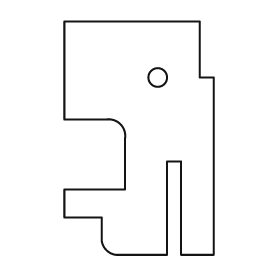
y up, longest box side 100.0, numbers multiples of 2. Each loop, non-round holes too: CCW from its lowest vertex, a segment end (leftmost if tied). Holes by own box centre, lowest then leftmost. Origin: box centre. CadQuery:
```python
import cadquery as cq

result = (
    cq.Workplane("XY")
    .moveTo(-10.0, -50.0)
    .lineTo(12.0, -50.0)
    .lineTo(12.0, -10.0)
    .lineTo(18.0, -10.0)
    .lineTo(18.0, -50.0)
    .lineTo(32.0, -50.0)
    .lineTo(32.0, 26.0)
    .lineTo(26.0, 26.0)
    .lineTo(26.0, 50.0)
    .lineTo(-32.0, 50.0)
    .lineTo(-32.0, 8.0)
    .lineTo(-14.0, 8.0)
    .threePointArc((-8.0, 6.0), (-6.0, 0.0))
    .lineTo(-6.0, -22.0)
    .lineTo(-32.0, -22.0)
    .lineTo(-32.0, -34.0)
    .lineTo(-16.0, -34.0)
    .lineTo(-16.0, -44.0)
    .threePointArc((-14.0, -48.0), (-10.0, -50.0))
    .close()
    .moveTo(8.0, 26.0)
    .circle(4.0)
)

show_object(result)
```